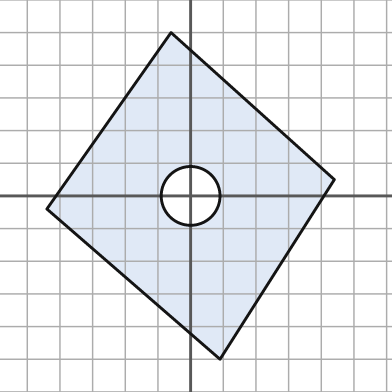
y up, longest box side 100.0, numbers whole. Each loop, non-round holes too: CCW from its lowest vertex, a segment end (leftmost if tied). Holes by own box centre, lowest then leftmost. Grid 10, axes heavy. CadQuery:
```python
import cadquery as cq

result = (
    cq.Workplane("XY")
    .moveTo(9.0, -50.0)
    .lineTo(44.0, 5.0)
    .lineTo(-6.0, 50.0)
    .lineTo(-44.0, -4.0)
    .close()
    .moveTo(0.0, 0.0)
    .circle(9.0)
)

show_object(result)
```